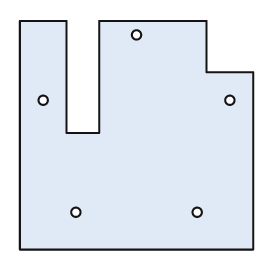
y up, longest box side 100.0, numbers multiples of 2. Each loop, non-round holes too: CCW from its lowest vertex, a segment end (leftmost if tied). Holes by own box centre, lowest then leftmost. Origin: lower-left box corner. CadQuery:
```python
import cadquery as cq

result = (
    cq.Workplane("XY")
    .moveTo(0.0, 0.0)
    .lineTo(100.0, 0.0)
    .lineTo(100.0, 76.0)
    .lineTo(80.0, 76.0)
    .lineTo(80.0, 98.0)
    .lineTo(34.0, 98.0)
    .lineTo(34.0, 50.0)
    .lineTo(20.0, 50.0)
    .lineTo(20.0, 98.0)
    .lineTo(0.0, 98.0)
    .close()
    .moveTo(24.0, 16.0)
    .circle(2.0)
    .moveTo(76.0, 16.0)
    .circle(2.0)
    .moveTo(10.0, 64.0)
    .circle(2.0)
    .moveTo(90.0, 64.0)
    .circle(2.0)
    .moveTo(50.0, 92.0)
    .circle(2.0)
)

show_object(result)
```